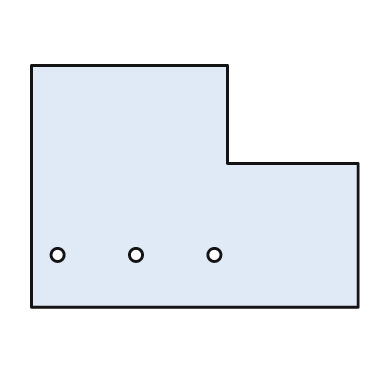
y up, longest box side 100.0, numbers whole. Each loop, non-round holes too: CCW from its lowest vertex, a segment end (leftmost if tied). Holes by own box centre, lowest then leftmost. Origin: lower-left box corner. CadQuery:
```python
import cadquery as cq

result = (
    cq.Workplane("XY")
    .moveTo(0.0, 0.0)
    .lineTo(100.0, 0.0)
    .lineTo(100.0, 44.0)
    .lineTo(60.0, 44.0)
    .lineTo(60.0, 74.0)
    .lineTo(0.0, 74.0)
    .close()
    .moveTo(8.0, 16.0)
    .circle(2.0)
    .moveTo(32.0, 16.0)
    .circle(2.0)
    .moveTo(56.0, 16.0)
    .circle(2.0)
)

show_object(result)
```